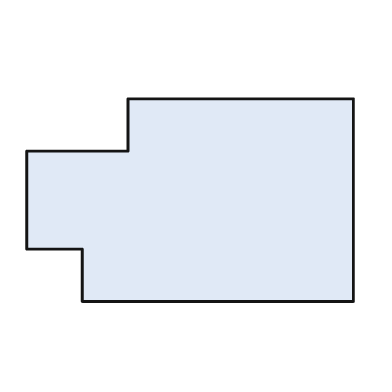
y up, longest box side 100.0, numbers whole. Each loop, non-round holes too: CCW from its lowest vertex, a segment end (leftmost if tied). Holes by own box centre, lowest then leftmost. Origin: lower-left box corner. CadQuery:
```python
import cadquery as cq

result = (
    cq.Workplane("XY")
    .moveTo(17.0, 0.0)
    .lineTo(100.0, 0.0)
    .lineTo(100.0, 62.0)
    .lineTo(31.0, 62.0)
    .lineTo(31.0, 46.0)
    .lineTo(0.0, 46.0)
    .lineTo(0.0, 16.0)
    .lineTo(17.0, 16.0)
    .close()
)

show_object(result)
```